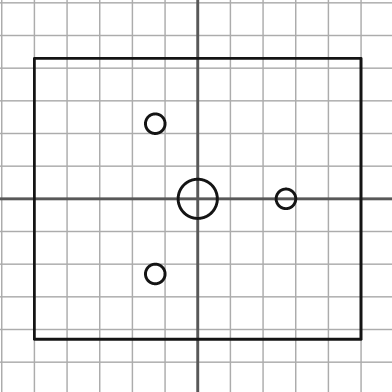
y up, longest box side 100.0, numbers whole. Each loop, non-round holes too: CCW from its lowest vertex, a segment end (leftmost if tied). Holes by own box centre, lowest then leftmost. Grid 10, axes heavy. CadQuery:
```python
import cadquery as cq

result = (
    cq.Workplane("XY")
    .moveTo(-50.0, -43.0)
    .lineTo(50.0, -43.0)
    .lineTo(50.0, 43.0)
    .lineTo(-50.0, 43.0)
    .close()
    .moveTo(-13.0, -23.0)
    .circle(3.0)
    .moveTo(0.0, 0.0)
    .circle(6.0)
    .moveTo(27.0, 0.0)
    .circle(3.0)
    .moveTo(-13.0, 23.0)
    .circle(3.0)
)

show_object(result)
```